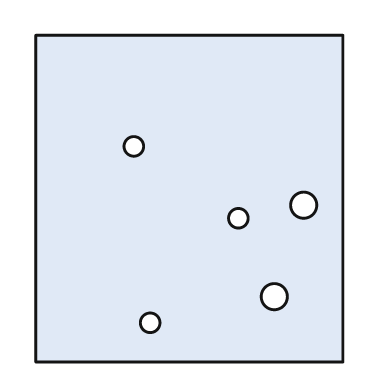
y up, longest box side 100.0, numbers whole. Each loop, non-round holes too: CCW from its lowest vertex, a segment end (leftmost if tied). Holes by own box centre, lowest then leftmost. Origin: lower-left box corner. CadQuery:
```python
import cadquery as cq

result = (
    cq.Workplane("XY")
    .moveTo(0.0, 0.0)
    .lineTo(94.0, 0.0)
    .lineTo(94.0, 100.0)
    .lineTo(0.0, 100.0)
    .close()
    .moveTo(35.0, 12.0)
    .circle(3.0)
    .moveTo(73.0, 20.0)
    .circle(4.0)
    .moveTo(62.0, 44.0)
    .circle(3.0)
    .moveTo(82.0, 48.0)
    .circle(4.0)
    .moveTo(30.0, 66.0)
    .circle(3.0)
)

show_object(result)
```